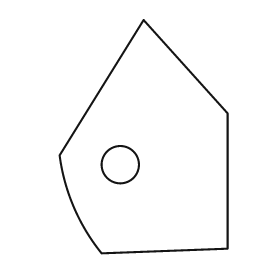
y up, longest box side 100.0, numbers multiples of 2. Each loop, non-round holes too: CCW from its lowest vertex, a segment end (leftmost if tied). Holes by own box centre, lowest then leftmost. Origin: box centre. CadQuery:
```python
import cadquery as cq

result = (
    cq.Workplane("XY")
    .moveTo(-18.0, -50.0)
    .lineTo(36.0, -48.0)
    .lineTo(36.0, 10.0)
    .lineTo(0.0, 50.0)
    .lineTo(-36.0, -8.0)
    .threePointArc((-30.0, -30.0), (-18.0, -50.0))
    .close()
    .moveTo(-10.0, -12.0)
    .circle(8.0)
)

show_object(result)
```